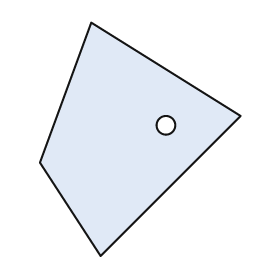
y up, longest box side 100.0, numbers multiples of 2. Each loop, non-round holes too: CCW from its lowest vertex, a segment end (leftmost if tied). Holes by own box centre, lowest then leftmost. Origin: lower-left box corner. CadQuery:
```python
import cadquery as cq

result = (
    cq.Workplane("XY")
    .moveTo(26.0, 0.0)
    .lineTo(86.0, 60.0)
    .lineTo(22.0, 100.0)
    .lineTo(0.0, 40.0)
    .close()
    .moveTo(54.0, 56.0)
    .circle(4.0)
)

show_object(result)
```